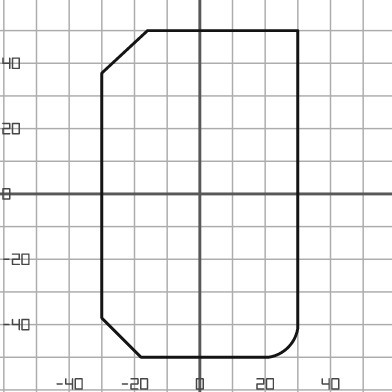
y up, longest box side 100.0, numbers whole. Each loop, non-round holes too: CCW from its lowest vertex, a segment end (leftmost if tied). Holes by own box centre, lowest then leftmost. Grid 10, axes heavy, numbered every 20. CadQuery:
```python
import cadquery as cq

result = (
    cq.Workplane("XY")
    .moveTo(-18.0, -50.0)
    .lineTo(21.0, -50.0)
    .threePointArc((27.0, -47.0), (30.0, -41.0))
    .lineTo(30.0, 50.0)
    .lineTo(-16.0, 50.0)
    .lineTo(-30.0, 37.0)
    .lineTo(-30.0, -38.0)
    .close()
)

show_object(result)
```